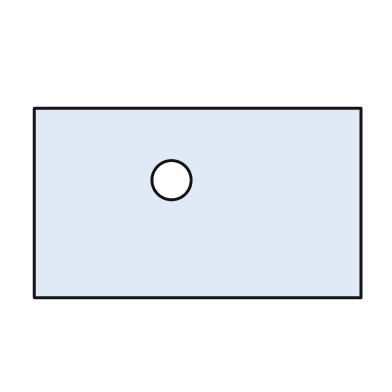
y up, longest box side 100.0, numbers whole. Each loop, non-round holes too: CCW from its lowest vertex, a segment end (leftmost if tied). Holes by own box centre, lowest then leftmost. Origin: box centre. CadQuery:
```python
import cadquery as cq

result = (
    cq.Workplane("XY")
    .moveTo(-50.0, -29.0)
    .lineTo(50.0, -29.0)
    .lineTo(50.0, 29.0)
    .lineTo(-50.0, 29.0)
    .close()
    .moveTo(-8.0, 7.0)
    .circle(6.0)
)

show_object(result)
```